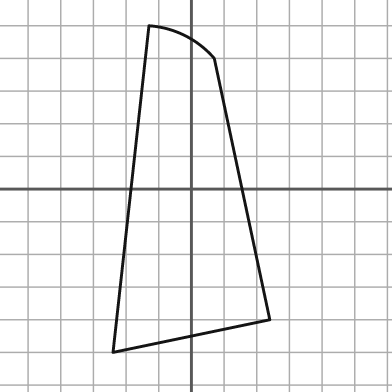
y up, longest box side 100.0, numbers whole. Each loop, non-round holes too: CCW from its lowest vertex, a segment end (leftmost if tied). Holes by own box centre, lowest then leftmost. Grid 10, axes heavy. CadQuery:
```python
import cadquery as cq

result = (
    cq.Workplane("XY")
    .moveTo(-24.0, -50.0)
    .lineTo(24.0, -40.0)
    .lineTo(7.0, 40.0)
    .threePointArc((-2.0, 47.0), (-13.0, 50.0))
    .close()
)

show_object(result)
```